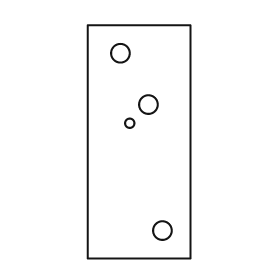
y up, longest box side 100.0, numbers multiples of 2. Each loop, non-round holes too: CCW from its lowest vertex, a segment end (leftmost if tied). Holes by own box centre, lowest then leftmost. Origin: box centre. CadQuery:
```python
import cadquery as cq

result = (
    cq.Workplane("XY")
    .moveTo(-22.0, -50.0)
    .lineTo(22.0, -50.0)
    .lineTo(22.0, 50.0)
    .lineTo(-22.0, 50.0)
    .close()
    .moveTo(10.0, -38.0)
    .circle(4.0)
    .moveTo(-4.0, 8.0)
    .circle(2.0)
    .moveTo(4.0, 16.0)
    .circle(4.0)
    .moveTo(-8.0, 38.0)
    .circle(4.0)
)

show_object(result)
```